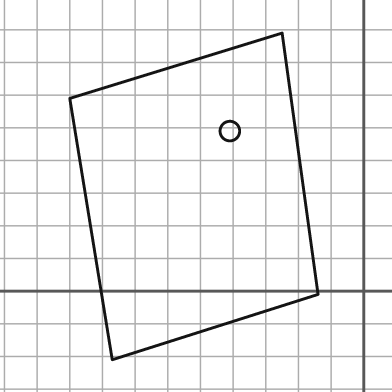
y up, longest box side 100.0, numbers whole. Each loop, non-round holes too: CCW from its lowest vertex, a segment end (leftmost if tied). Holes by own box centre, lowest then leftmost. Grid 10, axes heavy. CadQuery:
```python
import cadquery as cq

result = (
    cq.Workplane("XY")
    .moveTo(-77.0, -21.0)
    .lineTo(-14.0, -1.0)
    .lineTo(-25.0, 79.0)
    .lineTo(-90.0, 59.0)
    .close()
    .moveTo(-41.0, 49.0)
    .circle(3.0)
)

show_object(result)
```